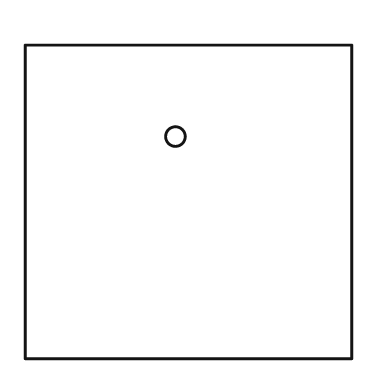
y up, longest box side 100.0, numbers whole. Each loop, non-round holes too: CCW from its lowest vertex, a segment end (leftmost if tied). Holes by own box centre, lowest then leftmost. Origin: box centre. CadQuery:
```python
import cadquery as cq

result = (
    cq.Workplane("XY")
    .moveTo(-50.0, -48.0)
    .lineTo(50.0, -48.0)
    .lineTo(50.0, 48.0)
    .lineTo(-50.0, 48.0)
    .close()
    .moveTo(-4.0, 20.0)
    .circle(3.0)
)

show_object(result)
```